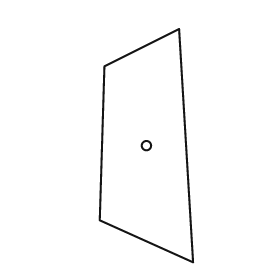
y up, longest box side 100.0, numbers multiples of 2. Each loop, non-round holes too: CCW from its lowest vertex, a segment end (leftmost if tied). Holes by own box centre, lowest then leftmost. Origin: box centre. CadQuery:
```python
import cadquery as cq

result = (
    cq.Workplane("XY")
    .moveTo(20.0, -50.0)
    .lineTo(14.0, 50.0)
    .lineTo(-18.0, 34.0)
    .lineTo(-20.0, -32.0)
    .close()
    .moveTo(0.0, 0.0)
    .circle(2.0)
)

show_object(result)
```